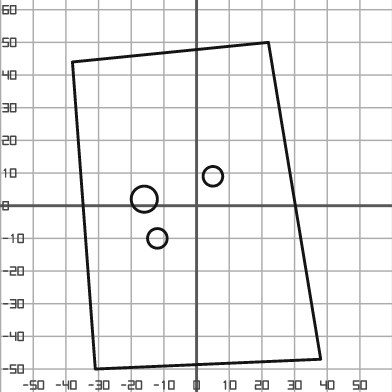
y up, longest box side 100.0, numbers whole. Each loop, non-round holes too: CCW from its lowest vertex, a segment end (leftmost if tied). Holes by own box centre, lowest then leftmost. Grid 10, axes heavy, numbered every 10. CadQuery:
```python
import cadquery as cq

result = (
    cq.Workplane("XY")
    .moveTo(-31.0, -50.0)
    .lineTo(38.0, -47.0)
    .lineTo(22.0, 50.0)
    .lineTo(-38.0, 44.0)
    .close()
    .moveTo(-12.0, -10.0)
    .circle(3.0)
    .moveTo(-16.0, 2.0)
    .circle(4.0)
    .moveTo(5.0, 9.0)
    .circle(3.0)
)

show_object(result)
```